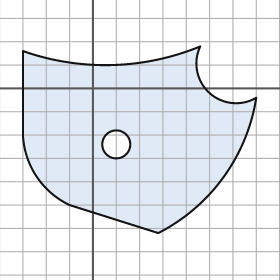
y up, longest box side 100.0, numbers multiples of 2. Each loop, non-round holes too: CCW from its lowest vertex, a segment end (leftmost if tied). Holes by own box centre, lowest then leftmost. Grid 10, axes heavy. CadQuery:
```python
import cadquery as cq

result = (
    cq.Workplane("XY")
    .moveTo(28.0, -62.0)
    .threePointArc((56.0, -38.0), (70.0, -4.0))
    .threePointArc((50.0, -2.0), (46.0, 18.0))
    .threePointArc((8.0, 10.0), (-30.0, 16.0))
    .lineTo(-30.0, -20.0)
    .threePointArc((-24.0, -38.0), (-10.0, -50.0))
    .close()
    .moveTo(10.0, -24.0)
    .circle(6.0)
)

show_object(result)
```